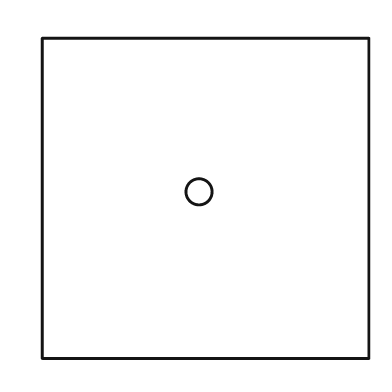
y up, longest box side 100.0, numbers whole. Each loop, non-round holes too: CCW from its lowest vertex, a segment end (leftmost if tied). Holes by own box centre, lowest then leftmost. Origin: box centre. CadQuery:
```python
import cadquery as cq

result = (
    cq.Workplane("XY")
    .moveTo(-50.0, -49.0)
    .lineTo(50.0, -49.0)
    .lineTo(50.0, 49.0)
    .lineTo(-50.0, 49.0)
    .close()
    .moveTo(-2.0, 2.0)
    .circle(4.0)
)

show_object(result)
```